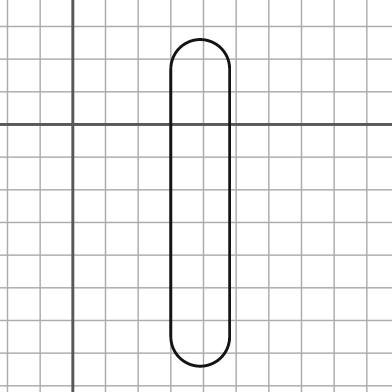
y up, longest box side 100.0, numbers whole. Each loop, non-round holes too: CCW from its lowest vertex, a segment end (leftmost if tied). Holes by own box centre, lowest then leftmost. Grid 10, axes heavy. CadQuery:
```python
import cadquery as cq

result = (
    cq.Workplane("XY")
    .moveTo(30.0, -65.0)
    .threePointArc((39.0, -74.0), (48.0, -65.0))
    .lineTo(48.0, 17.0)
    .threePointArc((39.0, 26.0), (30.0, 17.0))
    .close()
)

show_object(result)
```